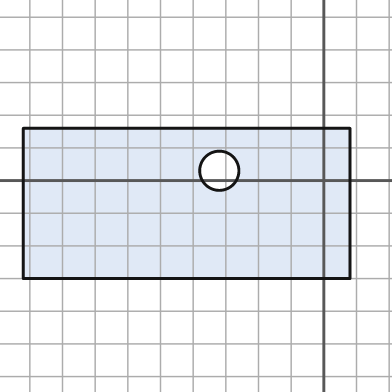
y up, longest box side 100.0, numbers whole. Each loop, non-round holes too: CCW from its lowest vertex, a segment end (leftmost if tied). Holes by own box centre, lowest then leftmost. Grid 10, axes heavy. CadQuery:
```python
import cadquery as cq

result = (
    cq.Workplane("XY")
    .moveTo(-92.0, -30.0)
    .lineTo(8.0, -30.0)
    .lineTo(8.0, 16.0)
    .lineTo(-92.0, 16.0)
    .close()
    .moveTo(-32.0, 3.0)
    .circle(6.0)
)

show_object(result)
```